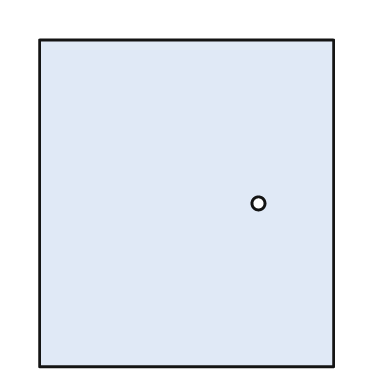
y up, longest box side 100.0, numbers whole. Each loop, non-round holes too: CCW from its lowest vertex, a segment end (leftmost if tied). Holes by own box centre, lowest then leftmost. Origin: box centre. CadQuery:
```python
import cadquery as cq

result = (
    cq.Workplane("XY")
    .moveTo(-45.0, -50.0)
    .lineTo(45.0, -50.0)
    .lineTo(45.0, 50.0)
    .lineTo(-45.0, 50.0)
    .close()
    .moveTo(22.0, 0.0)
    .circle(2.0)
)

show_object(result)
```